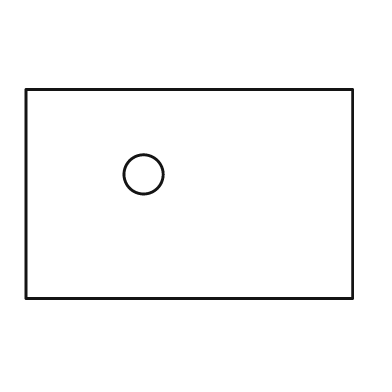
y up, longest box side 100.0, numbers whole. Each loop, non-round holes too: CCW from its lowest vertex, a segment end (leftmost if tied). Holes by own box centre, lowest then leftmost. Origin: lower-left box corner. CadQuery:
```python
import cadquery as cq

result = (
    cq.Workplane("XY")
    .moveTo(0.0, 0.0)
    .lineTo(100.0, 0.0)
    .lineTo(100.0, 64.0)
    .lineTo(0.0, 64.0)
    .close()
    .moveTo(36.0, 38.0)
    .circle(6.0)
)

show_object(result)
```